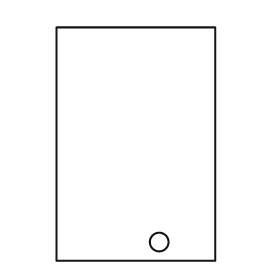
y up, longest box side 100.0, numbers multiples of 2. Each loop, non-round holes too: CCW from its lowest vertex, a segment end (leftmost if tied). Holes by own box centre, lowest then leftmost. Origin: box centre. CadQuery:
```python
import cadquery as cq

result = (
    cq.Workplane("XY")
    .moveTo(-34.0, -50.0)
    .lineTo(34.0, -50.0)
    .lineTo(34.0, 50.0)
    .lineTo(-34.0, 50.0)
    .close()
    .moveTo(10.0, -42.0)
    .circle(4.0)
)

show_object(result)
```